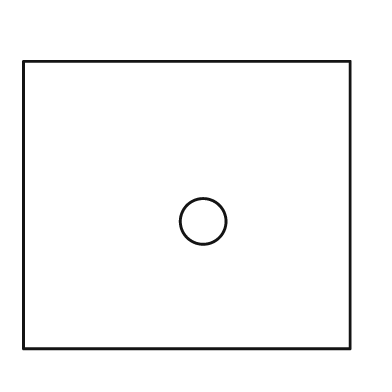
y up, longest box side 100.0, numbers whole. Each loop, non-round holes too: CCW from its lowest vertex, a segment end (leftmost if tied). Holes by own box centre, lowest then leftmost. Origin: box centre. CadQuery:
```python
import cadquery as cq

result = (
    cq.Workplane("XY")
    .moveTo(-50.0, -44.0)
    .lineTo(50.0, -44.0)
    .lineTo(50.0, 44.0)
    .lineTo(-50.0, 44.0)
    .close()
    .moveTo(5.0, -5.0)
    .circle(7.0)
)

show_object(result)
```